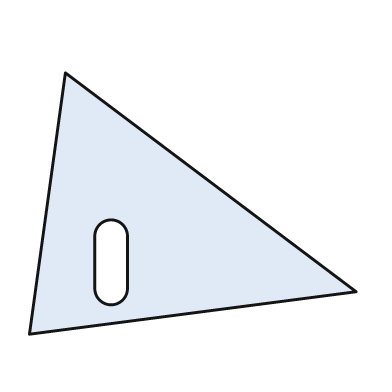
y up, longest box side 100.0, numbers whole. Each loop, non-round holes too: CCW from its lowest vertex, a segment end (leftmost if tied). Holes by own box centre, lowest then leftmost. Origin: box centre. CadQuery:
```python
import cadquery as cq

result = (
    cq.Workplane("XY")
    .moveTo(-50.0, -40.0)
    .lineTo(50.0, -27.0)
    .lineTo(-39.0, 40.0)
    .close()
    .moveTo(-30.0, -26.0)
    .threePointArc((-25.0, -31.0), (-20.0, -26.0))
    .lineTo(-20.0, -10.0)
    .threePointArc((-25.0, -5.0), (-30.0, -10.0))
    .close()
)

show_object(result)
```